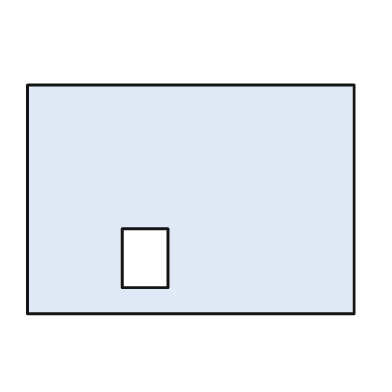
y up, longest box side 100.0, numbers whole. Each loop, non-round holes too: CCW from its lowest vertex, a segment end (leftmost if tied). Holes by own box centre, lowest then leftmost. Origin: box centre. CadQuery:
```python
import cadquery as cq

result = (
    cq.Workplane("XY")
    .moveTo(-50.0, -35.0)
    .lineTo(50.0, -35.0)
    .lineTo(50.0, 35.0)
    .lineTo(-50.0, 35.0)
    .close()
    .moveTo(-21.0, -27.0)
    .lineTo(-7.0, -27.0)
    .lineTo(-7.0, -9.0)
    .lineTo(-21.0, -9.0)
    .close()
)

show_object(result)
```